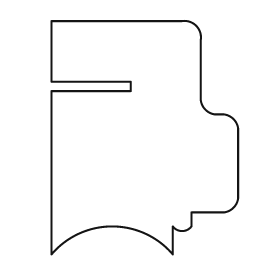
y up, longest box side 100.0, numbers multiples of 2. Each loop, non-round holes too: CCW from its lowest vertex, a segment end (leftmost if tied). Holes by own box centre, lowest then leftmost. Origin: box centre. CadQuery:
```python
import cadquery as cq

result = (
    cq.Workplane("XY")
    .moveTo(-40.0, -50.0)
    .threePointArc((-14.0, -38.0), (12.0, -50.0))
    .lineTo(12.0, -38.0)
    .threePointArc((16.0, -40.0), (20.0, -38.0))
    .lineTo(20.0, -32.0)
    .lineTo(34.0, -32.0)
    .threePointArc((38.0, -30.0), (40.0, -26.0))
    .lineTo(40.0, 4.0)
    .threePointArc((38.0, 8.0), (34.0, 10.0))
    .lineTo(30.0, 10.0)
    .threePointArc((26.0, 12.0), (24.0, 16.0))
    .lineTo(24.0, 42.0)
    .threePointArc((22.0, 48.0), (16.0, 50.0))
    .lineTo(-40.0, 50.0)
    .lineTo(-40.0, 24.0)
    .lineTo(-6.0, 24.0)
    .lineTo(-6.0, 20.0)
    .lineTo(-40.0, 20.0)
    .close()
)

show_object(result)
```